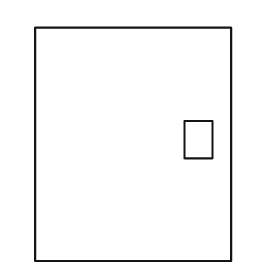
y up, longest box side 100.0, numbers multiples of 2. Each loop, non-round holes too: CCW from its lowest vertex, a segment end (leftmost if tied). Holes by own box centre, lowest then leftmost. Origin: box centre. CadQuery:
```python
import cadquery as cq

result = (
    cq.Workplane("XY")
    .moveTo(-42.0, -50.0)
    .lineTo(42.0, -50.0)
    .lineTo(42.0, 50.0)
    .lineTo(-42.0, 50.0)
    .close()
    .moveTo(22.0, -6.0)
    .lineTo(34.0, -6.0)
    .lineTo(34.0, 10.0)
    .lineTo(22.0, 10.0)
    .close()
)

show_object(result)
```